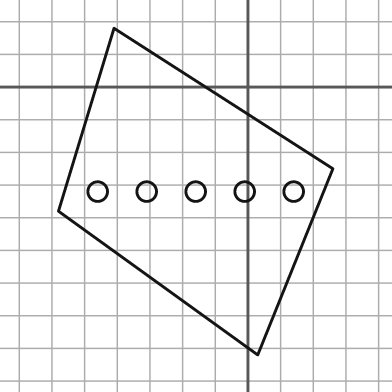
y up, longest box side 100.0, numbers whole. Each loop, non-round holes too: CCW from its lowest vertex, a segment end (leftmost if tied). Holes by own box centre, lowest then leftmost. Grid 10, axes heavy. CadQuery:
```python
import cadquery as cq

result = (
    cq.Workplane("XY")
    .moveTo(3.0, -82.0)
    .lineTo(26.0, -25.0)
    .lineTo(-41.0, 18.0)
    .lineTo(-58.0, -38.0)
    .close()
    .moveTo(-46.0, -32.0)
    .circle(3.0)
    .moveTo(-31.0, -32.0)
    .circle(3.0)
    .moveTo(-16.0, -32.0)
    .circle(3.0)
    .moveTo(-1.0, -32.0)
    .circle(3.0)
    .moveTo(14.0, -32.0)
    .circle(3.0)
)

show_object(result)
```